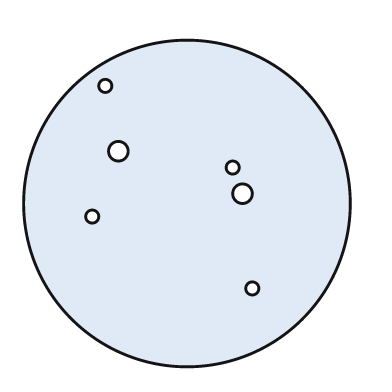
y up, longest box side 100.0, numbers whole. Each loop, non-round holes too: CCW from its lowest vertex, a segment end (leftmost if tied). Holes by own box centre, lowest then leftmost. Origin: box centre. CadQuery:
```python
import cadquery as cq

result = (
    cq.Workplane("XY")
    .moveTo(0.0, 0.0)
    .circle(50.0)
    .moveTo(20.0, -26.0)
    .circle(2.0)
    .moveTo(-29.0, -4.0)
    .circle(2.0)
    .moveTo(17.0, 3.0)
    .circle(3.0)
    .moveTo(14.0, 11.0)
    .circle(2.0)
    .moveTo(-21.0, 16.0)
    .circle(3.0)
    .moveTo(-25.0, 36.0)
    .circle(2.0)
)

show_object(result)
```